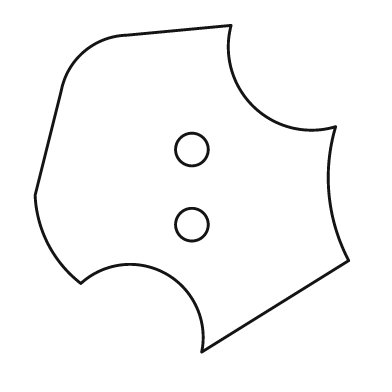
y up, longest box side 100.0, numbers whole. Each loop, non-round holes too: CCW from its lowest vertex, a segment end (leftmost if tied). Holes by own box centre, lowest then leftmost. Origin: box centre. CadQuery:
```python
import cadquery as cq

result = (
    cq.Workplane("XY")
    .moveTo(3.0, -50.0)
    .lineTo(48.0, -22.0)
    .threePointArc((42.0, -2.0), (44.0, 19.0))
    .threePointArc((19.0, 25.0), (12.0, 50.0))
    .lineTo(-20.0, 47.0)
    .threePointArc((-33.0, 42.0), (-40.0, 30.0))
    .lineTo(-48.0, -2.0)
    .threePointArc((-44.0, -17.0), (-34.0, -29.0))
    .threePointArc((-8.0, -26.0), (3.0, -50.0))
    .close()
    .moveTo(0.0, -11.0)
    .circle(5.0)
    .moveTo(0.0, 12.0)
    .circle(5.0)
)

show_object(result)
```